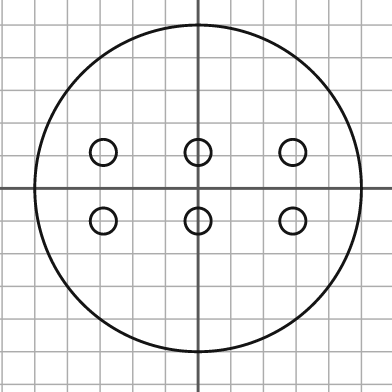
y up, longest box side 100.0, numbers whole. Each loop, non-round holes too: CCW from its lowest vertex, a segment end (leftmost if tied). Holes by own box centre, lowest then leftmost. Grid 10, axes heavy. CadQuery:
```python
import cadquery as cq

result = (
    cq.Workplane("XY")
    .moveTo(0.0, 0.0)
    .circle(50.0)
    .moveTo(-29.0, -10.0)
    .circle(4.0)
    .moveTo(0.0, -10.0)
    .circle(4.0)
    .moveTo(29.0, -10.0)
    .circle(4.0)
    .moveTo(-29.0, 11.0)
    .circle(4.0)
    .moveTo(0.0, 11.0)
    .circle(4.0)
    .moveTo(29.0, 11.0)
    .circle(4.0)
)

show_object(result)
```